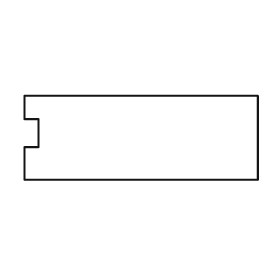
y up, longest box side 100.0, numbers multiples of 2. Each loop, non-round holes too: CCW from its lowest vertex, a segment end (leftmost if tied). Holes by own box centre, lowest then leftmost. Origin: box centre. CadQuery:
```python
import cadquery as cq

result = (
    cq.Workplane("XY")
    .moveTo(-50.0, -18.0)
    .lineTo(50.0, -18.0)
    .lineTo(50.0, 18.0)
    .lineTo(-50.0, 18.0)
    .lineTo(-50.0, 8.0)
    .lineTo(-44.0, 8.0)
    .lineTo(-44.0, -4.0)
    .lineTo(-50.0, -4.0)
    .close()
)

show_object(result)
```